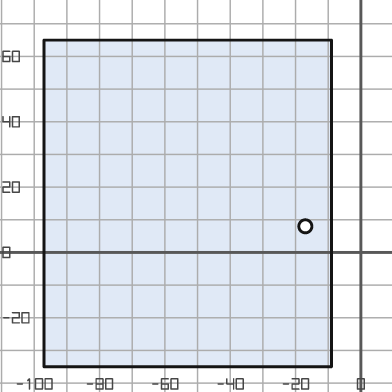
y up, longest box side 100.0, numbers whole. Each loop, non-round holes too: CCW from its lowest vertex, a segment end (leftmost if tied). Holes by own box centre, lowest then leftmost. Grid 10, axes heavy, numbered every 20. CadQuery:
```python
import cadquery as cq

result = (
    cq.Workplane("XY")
    .moveTo(-97.0, -35.0)
    .lineTo(-9.0, -35.0)
    .lineTo(-9.0, 65.0)
    .lineTo(-97.0, 65.0)
    .close()
    .moveTo(-17.0, 8.0)
    .circle(2.0)
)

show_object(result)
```